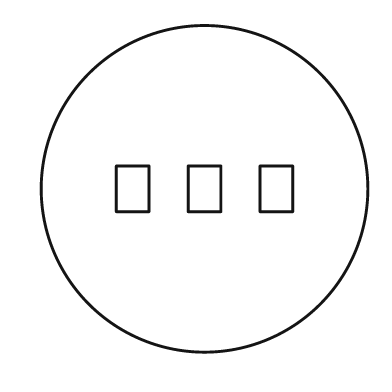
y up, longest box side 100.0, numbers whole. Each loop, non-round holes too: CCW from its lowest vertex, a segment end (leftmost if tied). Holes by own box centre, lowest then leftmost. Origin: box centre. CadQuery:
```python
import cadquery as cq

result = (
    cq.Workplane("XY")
    .moveTo(0.0, 0.0)
    .circle(50.0)
    .moveTo(-27.0, -7.0)
    .lineTo(-17.0, -7.0)
    .lineTo(-17.0, 7.0)
    .lineTo(-27.0, 7.0)
    .close()
    .moveTo(-5.0, -7.0)
    .lineTo(5.0, -7.0)
    .lineTo(5.0, 7.0)
    .lineTo(-5.0, 7.0)
    .close()
    .moveTo(17.0, -7.0)
    .lineTo(27.0, -7.0)
    .lineTo(27.0, 7.0)
    .lineTo(17.0, 7.0)
    .close()
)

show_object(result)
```